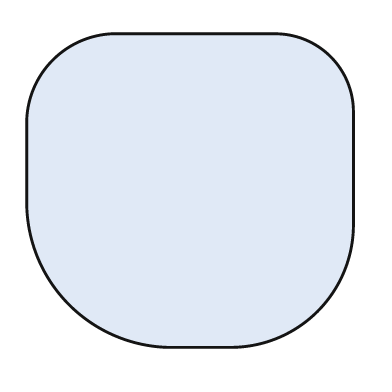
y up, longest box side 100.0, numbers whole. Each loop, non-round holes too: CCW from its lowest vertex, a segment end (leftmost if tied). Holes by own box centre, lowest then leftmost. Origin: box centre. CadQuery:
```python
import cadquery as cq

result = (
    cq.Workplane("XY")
    .moveTo(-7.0, -48.0)
    .lineTo(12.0, -48.0)
    .threePointArc((39.0, -37.0), (50.0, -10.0))
    .lineTo(50.0, 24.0)
    .threePointArc((43.0, 41.0), (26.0, 48.0))
    .lineTo(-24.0, 48.0)
    .threePointArc((-42.0, 40.0), (-50.0, 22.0))
    .lineTo(-50.0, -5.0)
    .threePointArc((-37.0, -35.0), (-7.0, -48.0))
    .close()
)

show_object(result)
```